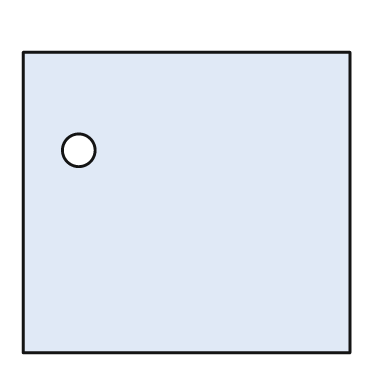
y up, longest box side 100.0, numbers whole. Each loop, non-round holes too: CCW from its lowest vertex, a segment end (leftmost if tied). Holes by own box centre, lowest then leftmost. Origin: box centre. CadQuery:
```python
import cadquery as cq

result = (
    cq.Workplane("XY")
    .moveTo(-50.0, -46.0)
    .lineTo(50.0, -46.0)
    .lineTo(50.0, 46.0)
    .lineTo(-50.0, 46.0)
    .close()
    .moveTo(-33.0, 16.0)
    .circle(5.0)
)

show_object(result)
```